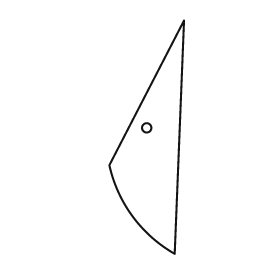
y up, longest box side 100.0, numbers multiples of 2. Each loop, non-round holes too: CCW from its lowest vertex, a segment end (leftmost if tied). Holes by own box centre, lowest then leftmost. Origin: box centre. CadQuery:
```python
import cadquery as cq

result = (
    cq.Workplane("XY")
    .moveTo(12.0, -50.0)
    .lineTo(16.0, 50.0)
    .lineTo(-16.0, -12.0)
    .threePointArc((-6.0, -34.0), (12.0, -50.0))
    .close()
    .moveTo(0.0, 4.0)
    .circle(2.0)
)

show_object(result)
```